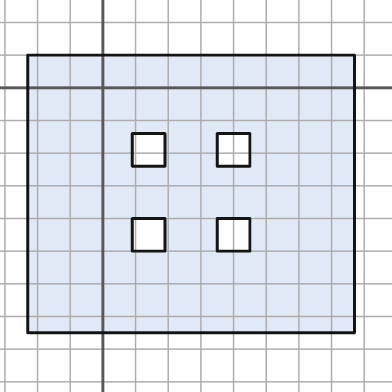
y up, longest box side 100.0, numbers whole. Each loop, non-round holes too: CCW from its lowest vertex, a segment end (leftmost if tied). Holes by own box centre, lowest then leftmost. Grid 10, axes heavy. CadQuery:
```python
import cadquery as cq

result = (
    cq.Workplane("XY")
    .moveTo(-23.0, -75.0)
    .lineTo(77.0, -75.0)
    .lineTo(77.0, 10.0)
    .lineTo(-23.0, 10.0)
    .close()
    .moveTo(9.0, -50.0)
    .lineTo(19.0, -50.0)
    .lineTo(19.0, -40.0)
    .lineTo(9.0, -40.0)
    .close()
    .moveTo(35.0, -50.0)
    .lineTo(45.0, -50.0)
    .lineTo(45.0, -40.0)
    .lineTo(35.0, -40.0)
    .close()
    .moveTo(9.0, -24.0)
    .lineTo(19.0, -24.0)
    .lineTo(19.0, -14.0)
    .lineTo(9.0, -14.0)
    .close()
    .moveTo(35.0, -24.0)
    .lineTo(45.0, -24.0)
    .lineTo(45.0, -14.0)
    .lineTo(35.0, -14.0)
    .close()
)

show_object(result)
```